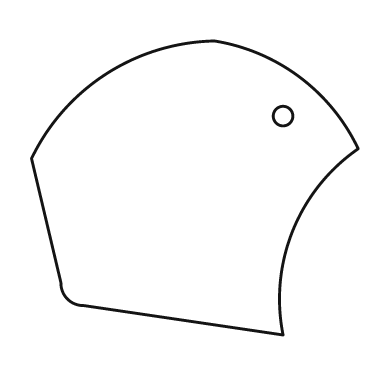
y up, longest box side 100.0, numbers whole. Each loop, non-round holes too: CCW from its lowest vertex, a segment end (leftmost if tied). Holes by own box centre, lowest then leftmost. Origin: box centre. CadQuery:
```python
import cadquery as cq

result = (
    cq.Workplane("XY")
    .moveTo(27.0, -45.0)
    .threePointArc((30.0, -13.0), (50.0, 12.0))
    .threePointArc((32.0, 34.0), (6.0, 45.0))
    .threePointArc((-27.0, 35.0), (-50.0, 9.0))
    .lineTo(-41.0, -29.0)
    .threePointArc((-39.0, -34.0), (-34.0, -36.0))
    .close()
    .moveTo(27.0, 22.0)
    .circle(3.0)
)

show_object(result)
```